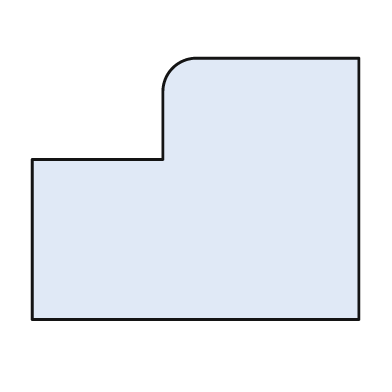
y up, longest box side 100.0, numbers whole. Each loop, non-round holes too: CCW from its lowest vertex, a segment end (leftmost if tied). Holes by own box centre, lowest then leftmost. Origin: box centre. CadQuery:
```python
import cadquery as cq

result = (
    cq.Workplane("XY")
    .moveTo(-50.0, -40.0)
    .lineTo(50.0, -40.0)
    .lineTo(50.0, 40.0)
    .lineTo(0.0, 40.0)
    .threePointArc((-7.0, 37.0), (-10.0, 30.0))
    .lineTo(-10.0, 9.0)
    .lineTo(-50.0, 9.0)
    .close()
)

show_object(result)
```